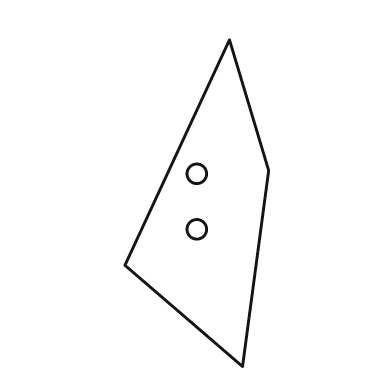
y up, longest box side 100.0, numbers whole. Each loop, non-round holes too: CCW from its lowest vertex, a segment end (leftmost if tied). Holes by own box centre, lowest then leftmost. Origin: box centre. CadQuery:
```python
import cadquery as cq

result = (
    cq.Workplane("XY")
    .moveTo(14.0, -50.0)
    .lineTo(22.0, 10.0)
    .lineTo(10.0, 50.0)
    .lineTo(-22.0, -19.0)
    .close()
    .moveTo(0.0, -8.0)
    .circle(3.0)
    .moveTo(0.0, 9.0)
    .circle(3.0)
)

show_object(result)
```